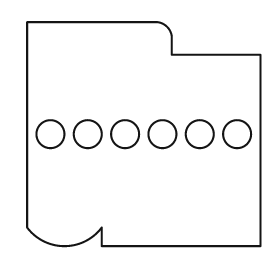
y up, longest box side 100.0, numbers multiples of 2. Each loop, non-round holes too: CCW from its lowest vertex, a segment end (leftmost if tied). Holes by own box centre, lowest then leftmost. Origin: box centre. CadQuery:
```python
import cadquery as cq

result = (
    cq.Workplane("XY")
    .moveTo(-18.0, -48.0)
    .lineTo(50.0, -48.0)
    .lineTo(50.0, 34.0)
    .lineTo(12.0, 34.0)
    .lineTo(12.0, 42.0)
    .threePointArc((10.0, 46.0), (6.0, 48.0))
    .lineTo(-50.0, 48.0)
    .lineTo(-50.0, -40.0)
    .threePointArc((-34.0, -48.0), (-18.0, -40.0))
    .close()
    .moveTo(-40.0, 0.0)
    .circle(6.0)
    .moveTo(-24.0, 0.0)
    .circle(6.0)
    .moveTo(-8.0, 0.0)
    .circle(6.0)
    .moveTo(8.0, 0.0)
    .circle(6.0)
    .moveTo(24.0, 0.0)
    .circle(6.0)
    .moveTo(40.0, 0.0)
    .circle(6.0)
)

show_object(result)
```